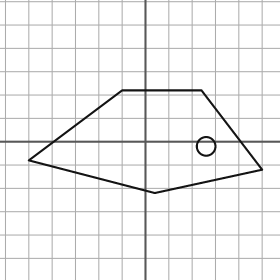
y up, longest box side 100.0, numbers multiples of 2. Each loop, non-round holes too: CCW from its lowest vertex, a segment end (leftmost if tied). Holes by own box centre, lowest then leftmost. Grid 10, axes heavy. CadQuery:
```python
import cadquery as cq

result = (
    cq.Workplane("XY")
    .moveTo(4.0, -22.0)
    .lineTo(50.0, -12.0)
    .lineTo(24.0, 22.0)
    .lineTo(-10.0, 22.0)
    .lineTo(-50.0, -8.0)
    .close()
    .moveTo(26.0, -2.0)
    .circle(4.0)
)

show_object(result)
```